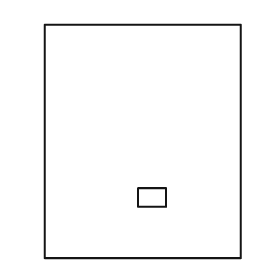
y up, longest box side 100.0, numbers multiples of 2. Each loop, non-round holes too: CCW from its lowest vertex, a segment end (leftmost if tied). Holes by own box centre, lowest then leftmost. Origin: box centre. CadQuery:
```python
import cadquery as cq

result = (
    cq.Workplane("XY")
    .moveTo(-42.0, -50.0)
    .lineTo(42.0, -50.0)
    .lineTo(42.0, 50.0)
    .lineTo(-42.0, 50.0)
    .close()
    .moveTo(-2.0, -28.0)
    .lineTo(10.0, -28.0)
    .lineTo(10.0, -20.0)
    .lineTo(-2.0, -20.0)
    .close()
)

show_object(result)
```